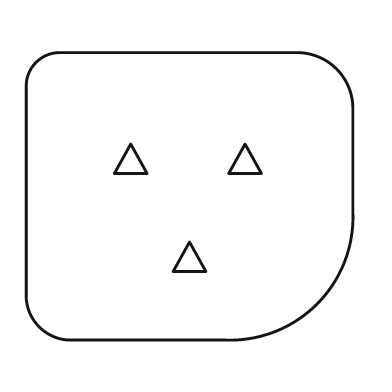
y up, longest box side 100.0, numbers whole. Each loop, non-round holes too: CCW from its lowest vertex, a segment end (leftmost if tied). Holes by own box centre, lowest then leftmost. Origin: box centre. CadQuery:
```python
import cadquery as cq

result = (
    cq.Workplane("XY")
    .moveTo(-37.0, -44.0)
    .lineTo(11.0, -44.0)
    .threePointArc((39.0, -33.0), (50.0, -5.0))
    .lineTo(50.0, 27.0)
    .threePointArc((45.0, 39.0), (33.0, 44.0))
    .lineTo(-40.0, 44.0)
    .threePointArc((-47.0, 41.0), (-50.0, 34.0))
    .lineTo(-50.0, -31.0)
    .threePointArc((-46.0, -40.0), (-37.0, -44.0))
    .close()
    .moveTo(-5.0, -23.0)
    .lineTo(5.0, -23.0)
    .lineTo(0.0, -14.0)
    .close()
    .moveTo(-23.0, 7.0)
    .lineTo(-13.0, 7.0)
    .lineTo(-18.0, 16.0)
    .close()
    .moveTo(12.0, 7.0)
    .lineTo(22.0, 7.0)
    .lineTo(17.0, 16.0)
    .close()
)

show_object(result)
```